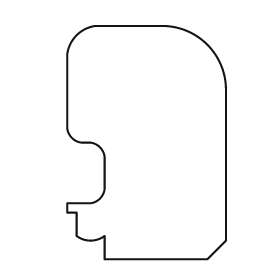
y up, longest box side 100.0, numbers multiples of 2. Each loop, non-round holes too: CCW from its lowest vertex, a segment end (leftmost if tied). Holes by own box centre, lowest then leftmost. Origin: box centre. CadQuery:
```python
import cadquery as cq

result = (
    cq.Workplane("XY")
    .moveTo(-18.0, -50.0)
    .lineTo(26.0, -50.0)
    .lineTo(34.0, -42.0)
    .lineTo(34.0, 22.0)
    .threePointArc((26.0, 42.0), (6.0, 50.0))
    .lineTo(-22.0, 50.0)
    .threePointArc((-30.0, 46.0), (-34.0, 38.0))
    .lineTo(-34.0, 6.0)
    .threePointArc((-32.0, 2.0), (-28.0, 0.0))
    .lineTo(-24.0, 0.0)
    .threePointArc((-20.0, -2.0), (-18.0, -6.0))
    .lineTo(-18.0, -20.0)
    .threePointArc((-20.0, -24.0), (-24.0, -26.0))
    .lineTo(-34.0, -26.0)
    .lineTo(-34.0, -30.0)
    .lineTo(-30.0, -30.0)
    .lineTo(-30.0, -40.0)
    .threePointArc((-24.0, -42.0), (-18.0, -40.0))
    .close()
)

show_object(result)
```